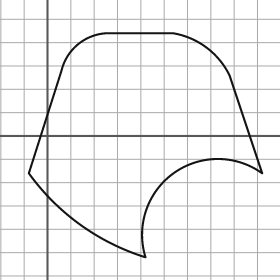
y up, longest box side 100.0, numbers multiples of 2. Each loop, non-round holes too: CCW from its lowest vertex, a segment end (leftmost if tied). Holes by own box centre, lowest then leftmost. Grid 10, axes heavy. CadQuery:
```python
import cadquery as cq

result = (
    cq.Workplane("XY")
    .moveTo(42.0, -52.0)
    .threePointArc((54.0, -16.0), (92.0, -16.0))
    .lineTo(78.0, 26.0)
    .threePointArc((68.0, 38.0), (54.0, 44.0))
    .lineTo(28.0, 44.0)
    .threePointArc((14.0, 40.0), (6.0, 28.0))
    .lineTo(-8.0, -16.0)
    .threePointArc((14.0, -38.0), (42.0, -52.0))
    .close()
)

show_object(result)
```